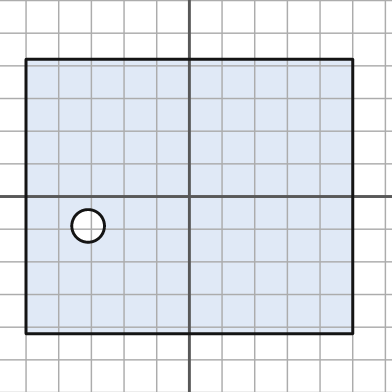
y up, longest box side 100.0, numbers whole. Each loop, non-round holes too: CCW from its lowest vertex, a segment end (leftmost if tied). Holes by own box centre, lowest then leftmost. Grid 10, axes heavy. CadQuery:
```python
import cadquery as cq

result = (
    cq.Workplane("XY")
    .moveTo(-50.0, -42.0)
    .lineTo(50.0, -42.0)
    .lineTo(50.0, 42.0)
    .lineTo(-50.0, 42.0)
    .close()
    .moveTo(-31.0, -9.0)
    .circle(5.0)
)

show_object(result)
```